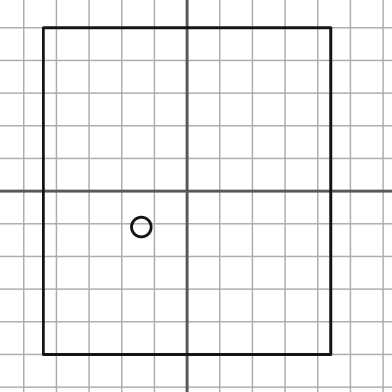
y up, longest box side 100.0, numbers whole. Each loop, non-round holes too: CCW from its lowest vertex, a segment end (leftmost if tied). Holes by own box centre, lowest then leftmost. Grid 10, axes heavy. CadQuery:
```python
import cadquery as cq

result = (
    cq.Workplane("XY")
    .moveTo(-44.0, -50.0)
    .lineTo(44.0, -50.0)
    .lineTo(44.0, 50.0)
    .lineTo(-44.0, 50.0)
    .close()
    .moveTo(-14.0, -11.0)
    .circle(3.0)
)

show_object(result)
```